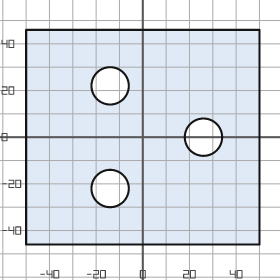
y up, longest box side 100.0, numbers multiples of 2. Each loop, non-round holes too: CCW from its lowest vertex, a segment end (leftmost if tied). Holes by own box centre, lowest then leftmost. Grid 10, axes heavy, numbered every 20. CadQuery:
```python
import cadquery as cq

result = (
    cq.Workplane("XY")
    .moveTo(-50.0, -46.0)
    .lineTo(50.0, -46.0)
    .lineTo(50.0, 46.0)
    .lineTo(-50.0, 46.0)
    .close()
    .moveTo(-14.0, -22.0)
    .circle(8.0)
    .moveTo(26.0, 0.0)
    .circle(8.0)
    .moveTo(-14.0, 22.0)
    .circle(8.0)
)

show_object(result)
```